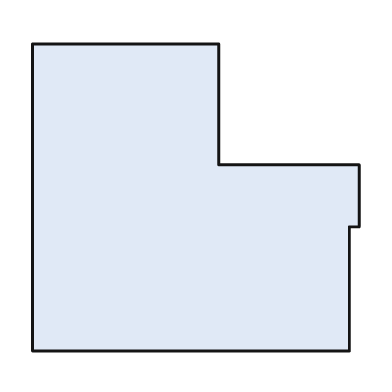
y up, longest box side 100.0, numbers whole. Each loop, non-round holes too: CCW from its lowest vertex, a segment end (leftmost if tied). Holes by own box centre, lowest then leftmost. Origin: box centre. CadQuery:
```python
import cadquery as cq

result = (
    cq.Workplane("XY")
    .moveTo(-50.0, -47.0)
    .lineTo(47.0, -47.0)
    .lineTo(47.0, -9.0)
    .lineTo(50.0, -9.0)
    .lineTo(50.0, 10.0)
    .lineTo(7.0, 10.0)
    .lineTo(7.0, 47.0)
    .lineTo(-50.0, 47.0)
    .close()
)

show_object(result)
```